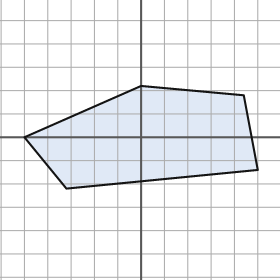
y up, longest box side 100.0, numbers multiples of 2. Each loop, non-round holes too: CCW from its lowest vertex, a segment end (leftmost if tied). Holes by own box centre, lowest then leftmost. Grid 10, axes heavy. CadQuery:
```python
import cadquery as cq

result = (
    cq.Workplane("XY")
    .moveTo(-32.0, -22.0)
    .lineTo(50.0, -14.0)
    .lineTo(44.0, 18.0)
    .lineTo(0.0, 22.0)
    .lineTo(-50.0, 0.0)
    .close()
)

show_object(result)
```